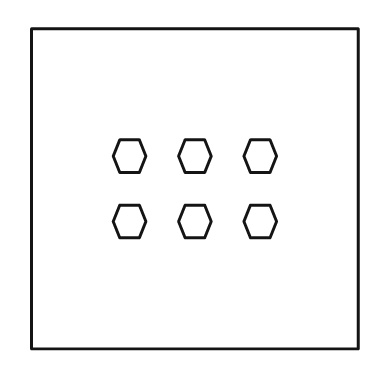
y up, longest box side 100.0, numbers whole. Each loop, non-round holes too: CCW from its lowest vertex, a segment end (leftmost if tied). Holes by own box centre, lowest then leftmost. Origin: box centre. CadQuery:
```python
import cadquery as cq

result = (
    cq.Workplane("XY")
    .moveTo(-50.0, -49.0)
    .lineTo(50.0, -49.0)
    .lineTo(50.0, 49.0)
    .lineTo(-50.0, 49.0)
    .close()
    .moveTo(-23.0, -15.0)
    .lineTo(-17.0, -15.0)
    .lineTo(-15.0, -10.0)
    .lineTo(-17.0, -5.0)
    .lineTo(-23.0, -5.0)
    .lineTo(-25.0, -10.0)
    .close()
    .moveTo(-3.0, -15.0)
    .lineTo(3.0, -15.0)
    .lineTo(5.0, -10.0)
    .lineTo(3.0, -5.0)
    .lineTo(-3.0, -5.0)
    .lineTo(-5.0, -10.0)
    .close()
    .moveTo(17.0, -15.0)
    .lineTo(23.0, -15.0)
    .lineTo(25.0, -10.0)
    .lineTo(23.0, -5.0)
    .lineTo(17.0, -5.0)
    .lineTo(15.0, -10.0)
    .close()
    .moveTo(-23.0, 5.0)
    .lineTo(-17.0, 5.0)
    .lineTo(-15.0, 10.0)
    .lineTo(-17.0, 15.0)
    .lineTo(-23.0, 15.0)
    .lineTo(-25.0, 10.0)
    .close()
    .moveTo(-3.0, 5.0)
    .lineTo(3.0, 5.0)
    .lineTo(5.0, 10.0)
    .lineTo(3.0, 15.0)
    .lineTo(-3.0, 15.0)
    .lineTo(-5.0, 10.0)
    .close()
    .moveTo(17.0, 5.0)
    .lineTo(23.0, 5.0)
    .lineTo(25.0, 10.0)
    .lineTo(23.0, 15.0)
    .lineTo(17.0, 15.0)
    .lineTo(15.0, 10.0)
    .close()
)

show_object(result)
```